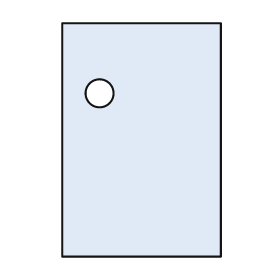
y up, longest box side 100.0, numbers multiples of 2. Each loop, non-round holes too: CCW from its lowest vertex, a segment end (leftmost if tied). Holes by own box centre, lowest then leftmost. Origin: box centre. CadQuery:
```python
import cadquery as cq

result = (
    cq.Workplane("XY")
    .moveTo(-34.0, -50.0)
    .lineTo(34.0, -50.0)
    .lineTo(34.0, 50.0)
    .lineTo(-34.0, 50.0)
    .close()
    .moveTo(-18.0, 20.0)
    .circle(6.0)
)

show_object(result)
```